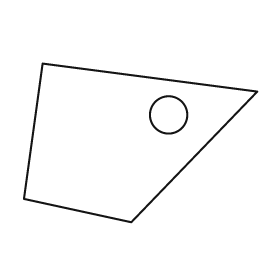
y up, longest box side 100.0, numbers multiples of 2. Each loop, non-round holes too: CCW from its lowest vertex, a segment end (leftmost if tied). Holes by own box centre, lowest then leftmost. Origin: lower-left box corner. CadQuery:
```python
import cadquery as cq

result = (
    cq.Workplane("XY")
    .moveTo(46.0, 0.0)
    .lineTo(100.0, 56.0)
    .lineTo(8.0, 68.0)
    .lineTo(0.0, 10.0)
    .close()
    .moveTo(62.0, 46.0)
    .circle(8.0)
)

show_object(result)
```